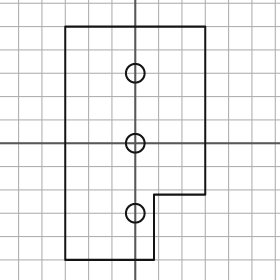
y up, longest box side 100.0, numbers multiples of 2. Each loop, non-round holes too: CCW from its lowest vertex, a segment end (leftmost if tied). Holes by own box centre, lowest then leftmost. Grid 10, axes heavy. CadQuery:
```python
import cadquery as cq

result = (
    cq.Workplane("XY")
    .moveTo(-30.0, -50.0)
    .lineTo(8.0, -50.0)
    .lineTo(8.0, -22.0)
    .lineTo(30.0, -22.0)
    .lineTo(30.0, 50.0)
    .lineTo(-30.0, 50.0)
    .close()
    .moveTo(0.0, -30.0)
    .circle(4.0)
    .moveTo(0.0, 0.0)
    .circle(4.0)
    .moveTo(0.0, 30.0)
    .circle(4.0)
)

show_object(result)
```